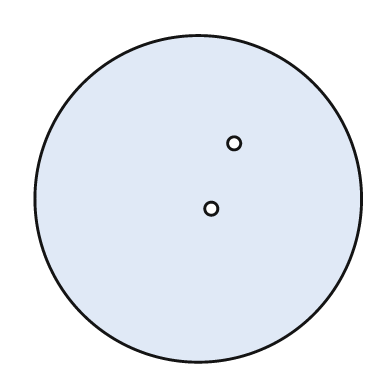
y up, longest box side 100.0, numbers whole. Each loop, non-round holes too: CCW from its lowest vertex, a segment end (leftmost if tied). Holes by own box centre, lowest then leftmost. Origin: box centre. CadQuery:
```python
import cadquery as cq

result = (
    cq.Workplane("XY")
    .moveTo(0.0, 0.0)
    .circle(50.0)
    .moveTo(4.0, -3.0)
    .circle(2.0)
    .moveTo(11.0, 17.0)
    .circle(2.0)
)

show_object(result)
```